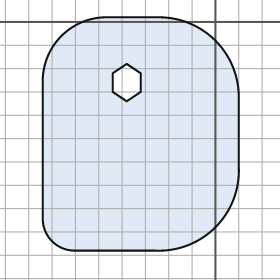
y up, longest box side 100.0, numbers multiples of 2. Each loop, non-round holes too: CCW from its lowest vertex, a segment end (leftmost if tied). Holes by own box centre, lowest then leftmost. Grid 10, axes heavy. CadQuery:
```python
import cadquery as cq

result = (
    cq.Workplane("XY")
    .moveTo(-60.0, -98.0)
    .lineTo(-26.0, -98.0)
    .threePointArc((0.0, -88.0), (10.0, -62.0))
    .lineTo(10.0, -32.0)
    .threePointArc((0.0, -8.0), (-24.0, 2.0))
    .lineTo(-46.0, 2.0)
    .threePointArc((-66.0, -6.0), (-74.0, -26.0))
    .lineTo(-74.0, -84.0)
    .threePointArc((-70.0, -94.0), (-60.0, -98.0))
    .close()
    .moveTo(-38.0, -34.0)
    .lineTo(-32.0, -30.0)
    .lineTo(-32.0, -22.0)
    .lineTo(-38.0, -18.0)
    .lineTo(-44.0, -22.0)
    .lineTo(-44.0, -30.0)
    .close()
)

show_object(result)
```